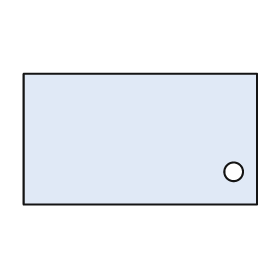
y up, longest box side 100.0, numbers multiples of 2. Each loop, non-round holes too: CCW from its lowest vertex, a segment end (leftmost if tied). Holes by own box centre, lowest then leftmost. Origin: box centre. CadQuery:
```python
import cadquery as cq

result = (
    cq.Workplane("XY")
    .moveTo(-50.0, -28.0)
    .lineTo(50.0, -28.0)
    .lineTo(50.0, 28.0)
    .lineTo(-50.0, 28.0)
    .close()
    .moveTo(40.0, -14.0)
    .circle(4.0)
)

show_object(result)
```